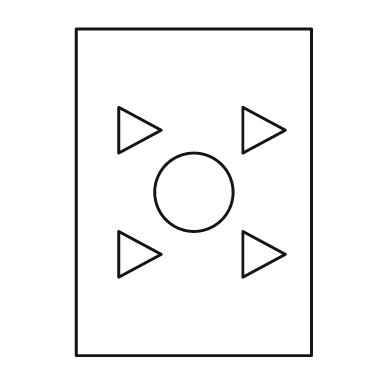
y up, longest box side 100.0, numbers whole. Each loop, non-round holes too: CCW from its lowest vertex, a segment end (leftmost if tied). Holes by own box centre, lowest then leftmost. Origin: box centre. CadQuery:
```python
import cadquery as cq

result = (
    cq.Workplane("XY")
    .moveTo(-36.0, -50.0)
    .lineTo(36.0, -50.0)
    .lineTo(36.0, 50.0)
    .lineTo(-36.0, 50.0)
    .close()
    .moveTo(-23.0, -26.0)
    .lineTo(-10.0, -19.0)
    .lineTo(-23.0, -12.0)
    .close()
    .moveTo(15.0, -26.0)
    .lineTo(28.0, -19.0)
    .lineTo(15.0, -12.0)
    .close()
    .moveTo(0.0, 0.0)
    .circle(12.0)
    .moveTo(-23.0, 12.0)
    .lineTo(-10.0, 19.0)
    .lineTo(-23.0, 26.0)
    .close()
    .moveTo(15.0, 12.0)
    .lineTo(28.0, 19.0)
    .lineTo(15.0, 26.0)
    .close()
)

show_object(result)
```